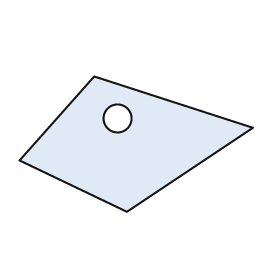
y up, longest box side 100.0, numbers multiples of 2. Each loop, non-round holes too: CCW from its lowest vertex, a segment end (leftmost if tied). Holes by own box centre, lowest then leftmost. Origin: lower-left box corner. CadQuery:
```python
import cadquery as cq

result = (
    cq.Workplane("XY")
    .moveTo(46.0, 0.0)
    .lineTo(100.0, 36.0)
    .lineTo(32.0, 58.0)
    .lineTo(0.0, 22.0)
    .close()
    .moveTo(42.0, 40.0)
    .circle(6.0)
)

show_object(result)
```